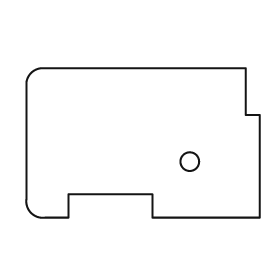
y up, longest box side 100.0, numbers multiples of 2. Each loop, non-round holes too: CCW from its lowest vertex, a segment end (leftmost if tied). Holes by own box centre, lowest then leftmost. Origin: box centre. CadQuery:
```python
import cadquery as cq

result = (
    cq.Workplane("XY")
    .moveTo(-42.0, -32.0)
    .lineTo(-32.0, -32.0)
    .lineTo(-32.0, -22.0)
    .lineTo(4.0, -22.0)
    .lineTo(4.0, -32.0)
    .lineTo(50.0, -32.0)
    .lineTo(50.0, 12.0)
    .lineTo(44.0, 12.0)
    .lineTo(44.0, 32.0)
    .lineTo(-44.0, 32.0)
    .threePointArc((-48.0, 30.0), (-50.0, 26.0))
    .lineTo(-50.0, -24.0)
    .threePointArc((-48.0, -30.0), (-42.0, -32.0))
    .close()
    .moveTo(20.0, -8.0)
    .circle(4.0)
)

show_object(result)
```